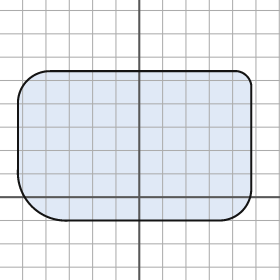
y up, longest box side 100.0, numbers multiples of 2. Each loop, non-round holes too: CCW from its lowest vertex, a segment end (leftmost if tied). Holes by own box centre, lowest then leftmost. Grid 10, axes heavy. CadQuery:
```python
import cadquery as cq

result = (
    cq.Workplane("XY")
    .moveTo(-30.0, -10.0)
    .lineTo(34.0, -10.0)
    .threePointArc((44.0, -6.0), (48.0, 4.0))
    .lineTo(48.0, 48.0)
    .threePointArc((46.0, 52.0), (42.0, 54.0))
    .lineTo(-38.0, 54.0)
    .threePointArc((-48.0, 50.0), (-52.0, 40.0))
    .lineTo(-52.0, 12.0)
    .threePointArc((-46.0, -4.0), (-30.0, -10.0))
    .close()
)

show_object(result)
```